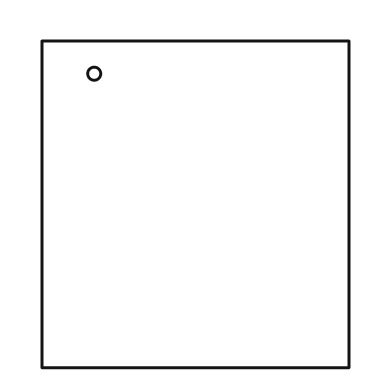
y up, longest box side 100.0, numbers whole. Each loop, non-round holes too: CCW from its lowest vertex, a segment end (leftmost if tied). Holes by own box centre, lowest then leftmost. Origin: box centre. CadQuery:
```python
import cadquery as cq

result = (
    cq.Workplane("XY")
    .moveTo(-47.0, -50.0)
    .lineTo(47.0, -50.0)
    .lineTo(47.0, 50.0)
    .lineTo(-47.0, 50.0)
    .close()
    .moveTo(-31.0, 40.0)
    .circle(2.0)
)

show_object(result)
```